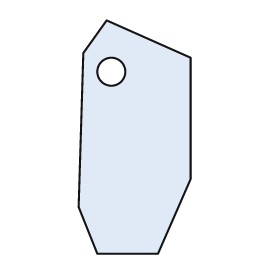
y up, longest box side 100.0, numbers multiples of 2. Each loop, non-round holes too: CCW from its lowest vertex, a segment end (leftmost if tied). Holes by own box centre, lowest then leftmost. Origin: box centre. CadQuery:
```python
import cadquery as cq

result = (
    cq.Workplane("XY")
    .moveTo(-16.0, -50.0)
    .lineTo(10.0, -50.0)
    .lineTo(24.0, -18.0)
    .lineTo(24.0, 34.0)
    .lineTo(-12.0, 50.0)
    .lineTo(-22.0, 36.0)
    .lineTo(-24.0, -30.0)
    .close()
    .moveTo(-10.0, 28.0)
    .circle(6.0)
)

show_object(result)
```